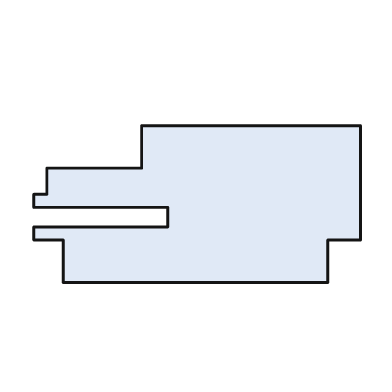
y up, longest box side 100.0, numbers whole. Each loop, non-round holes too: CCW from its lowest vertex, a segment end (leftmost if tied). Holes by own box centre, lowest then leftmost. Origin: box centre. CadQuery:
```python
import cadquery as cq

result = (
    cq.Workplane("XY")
    .moveTo(-41.0, -24.0)
    .lineTo(40.0, -24.0)
    .lineTo(40.0, -11.0)
    .lineTo(50.0, -11.0)
    .lineTo(50.0, 24.0)
    .lineTo(-17.0, 24.0)
    .lineTo(-17.0, 11.0)
    .lineTo(-46.0, 11.0)
    .lineTo(-46.0, 3.0)
    .lineTo(-50.0, 3.0)
    .lineTo(-50.0, -1.0)
    .lineTo(-9.0, -1.0)
    .lineTo(-9.0, -7.0)
    .lineTo(-50.0, -7.0)
    .lineTo(-50.0, -11.0)
    .lineTo(-41.0, -11.0)
    .close()
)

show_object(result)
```